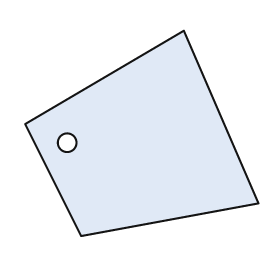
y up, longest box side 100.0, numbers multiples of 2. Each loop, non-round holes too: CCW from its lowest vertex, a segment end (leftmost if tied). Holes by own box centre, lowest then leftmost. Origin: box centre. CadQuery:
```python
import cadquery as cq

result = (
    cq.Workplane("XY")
    .moveTo(-26.0, -44.0)
    .lineTo(50.0, -30.0)
    .lineTo(18.0, 44.0)
    .lineTo(-50.0, 4.0)
    .close()
    .moveTo(-32.0, -4.0)
    .circle(4.0)
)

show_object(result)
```